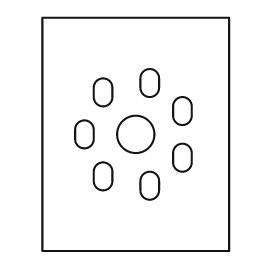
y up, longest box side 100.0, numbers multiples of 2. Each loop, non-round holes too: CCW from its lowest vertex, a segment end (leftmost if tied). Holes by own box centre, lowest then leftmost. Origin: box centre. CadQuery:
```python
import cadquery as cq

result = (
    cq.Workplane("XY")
    .moveTo(-40.0, -50.0)
    .lineTo(40.0, -50.0)
    .lineTo(40.0, 50.0)
    .lineTo(-40.0, 50.0)
    .close()
    .moveTo(2.0, -24.0)
    .threePointArc((6.0, -28.0), (10.0, -24.0))
    .lineTo(10.0, -20.0)
    .threePointArc((6.0, -16.0), (2.0, -20.0))
    .close()
    .moveTo(-18.0, -20.0)
    .threePointArc((-14.0, -24.0), (-10.0, -20.0))
    .lineTo(-10.0, -16.0)
    .threePointArc((-14.0, -12.0), (-18.0, -16.0))
    .close()
    .moveTo(16.0, -12.0)
    .threePointArc((20.0, -16.0), (24.0, -12.0))
    .lineTo(24.0, -8.0)
    .threePointArc((20.0, -4.0), (16.0, -8.0))
    .close()
    .moveTo(-26.0, -2.0)
    .threePointArc((-22.0, -6.0), (-18.0, -2.0))
    .lineTo(-18.0, 2.0)
    .threePointArc((-22.0, 6.0), (-26.0, 2.0))
    .close()
    .moveTo(0.0, 0.0)
    .circle(8.0)
    .moveTo(16.0, 8.0)
    .threePointArc((20.0, 4.0), (24.0, 8.0))
    .lineTo(24.0, 12.0)
    .threePointArc((20.0, 16.0), (16.0, 12.0))
    .close()
    .moveTo(-18.0, 16.0)
    .threePointArc((-14.0, 12.0), (-10.0, 16.0))
    .lineTo(-10.0, 20.0)
    .threePointArc((-14.0, 24.0), (-18.0, 20.0))
    .close()
    .moveTo(2.0, 20.0)
    .threePointArc((6.0, 16.0), (10.0, 20.0))
    .lineTo(10.0, 24.0)
    .threePointArc((6.0, 28.0), (2.0, 24.0))
    .close()
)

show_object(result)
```